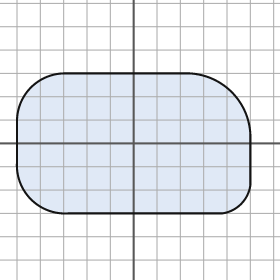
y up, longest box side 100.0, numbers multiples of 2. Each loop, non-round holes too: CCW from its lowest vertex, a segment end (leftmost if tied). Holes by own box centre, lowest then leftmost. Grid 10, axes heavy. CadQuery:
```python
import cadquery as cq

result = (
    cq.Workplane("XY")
    .moveTo(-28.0, -30.0)
    .lineTo(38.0, -30.0)
    .threePointArc((46.0, -26.0), (50.0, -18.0))
    .lineTo(50.0, 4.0)
    .threePointArc((42.0, 22.0), (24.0, 30.0))
    .lineTo(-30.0, 30.0)
    .threePointArc((-44.0, 24.0), (-50.0, 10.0))
    .lineTo(-50.0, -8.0)
    .threePointArc((-44.0, -24.0), (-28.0, -30.0))
    .close()
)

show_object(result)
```